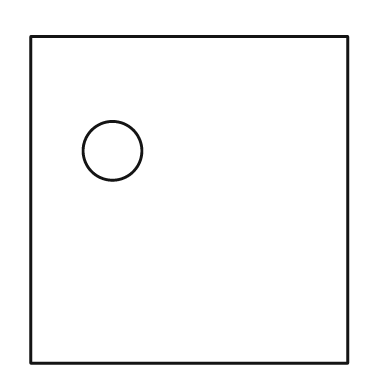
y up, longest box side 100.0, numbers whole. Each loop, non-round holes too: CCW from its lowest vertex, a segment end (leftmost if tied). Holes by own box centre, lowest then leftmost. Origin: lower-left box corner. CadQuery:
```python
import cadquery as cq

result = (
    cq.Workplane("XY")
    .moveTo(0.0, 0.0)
    .lineTo(97.0, 0.0)
    .lineTo(97.0, 100.0)
    .lineTo(0.0, 100.0)
    .close()
    .moveTo(25.0, 65.0)
    .circle(9.0)
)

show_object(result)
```